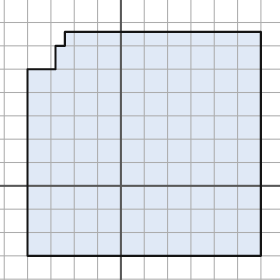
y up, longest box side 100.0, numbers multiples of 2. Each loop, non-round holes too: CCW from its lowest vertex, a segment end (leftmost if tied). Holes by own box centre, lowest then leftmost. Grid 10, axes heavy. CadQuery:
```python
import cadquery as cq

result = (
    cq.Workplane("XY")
    .moveTo(-40.0, -30.0)
    .lineTo(60.0, -30.0)
    .lineTo(60.0, 66.0)
    .lineTo(-24.0, 66.0)
    .lineTo(-24.0, 60.0)
    .lineTo(-28.0, 60.0)
    .lineTo(-28.0, 50.0)
    .lineTo(-40.0, 50.0)
    .close()
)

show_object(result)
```